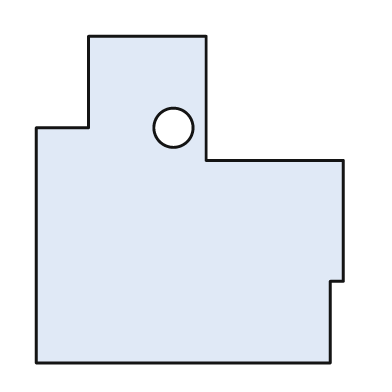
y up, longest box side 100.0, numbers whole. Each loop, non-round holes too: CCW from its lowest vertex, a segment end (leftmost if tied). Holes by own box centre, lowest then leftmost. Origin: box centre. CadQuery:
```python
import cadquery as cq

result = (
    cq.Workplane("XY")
    .moveTo(-47.0, -50.0)
    .lineTo(43.0, -50.0)
    .lineTo(43.0, -25.0)
    .lineTo(47.0, -25.0)
    .lineTo(47.0, 12.0)
    .lineTo(5.0, 12.0)
    .lineTo(5.0, 50.0)
    .lineTo(-31.0, 50.0)
    .lineTo(-31.0, 22.0)
    .lineTo(-47.0, 22.0)
    .close()
    .moveTo(-5.0, 22.0)
    .circle(6.0)
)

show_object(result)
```